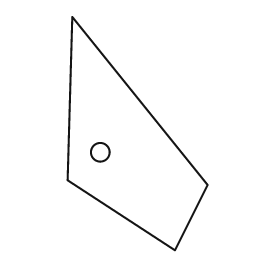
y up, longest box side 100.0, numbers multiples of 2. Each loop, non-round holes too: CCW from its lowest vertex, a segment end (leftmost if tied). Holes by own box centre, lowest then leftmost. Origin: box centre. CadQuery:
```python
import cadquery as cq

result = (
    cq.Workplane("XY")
    .moveTo(16.0, -50.0)
    .lineTo(30.0, -22.0)
    .lineTo(-28.0, 50.0)
    .lineTo(-30.0, -20.0)
    .close()
    .moveTo(-16.0, -8.0)
    .circle(4.0)
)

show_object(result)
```